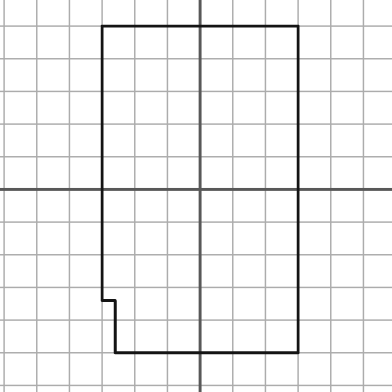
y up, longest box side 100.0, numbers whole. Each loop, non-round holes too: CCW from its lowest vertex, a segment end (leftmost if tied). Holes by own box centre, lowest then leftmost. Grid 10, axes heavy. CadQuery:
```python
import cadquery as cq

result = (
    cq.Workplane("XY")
    .moveTo(-26.0, -50.0)
    .lineTo(30.0, -50.0)
    .lineTo(30.0, 50.0)
    .lineTo(-30.0, 50.0)
    .lineTo(-30.0, -34.0)
    .lineTo(-26.0, -34.0)
    .close()
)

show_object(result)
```